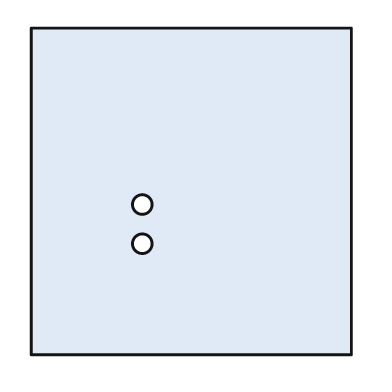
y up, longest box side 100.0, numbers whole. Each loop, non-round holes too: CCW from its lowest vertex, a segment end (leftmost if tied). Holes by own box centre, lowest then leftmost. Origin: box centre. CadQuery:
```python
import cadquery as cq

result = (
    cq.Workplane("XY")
    .moveTo(-49.0, -50.0)
    .lineTo(49.0, -50.0)
    .lineTo(49.0, 50.0)
    .lineTo(-49.0, 50.0)
    .close()
    .moveTo(-15.0, -16.0)
    .circle(3.0)
    .moveTo(-15.0, -4.0)
    .circle(3.0)
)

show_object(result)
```